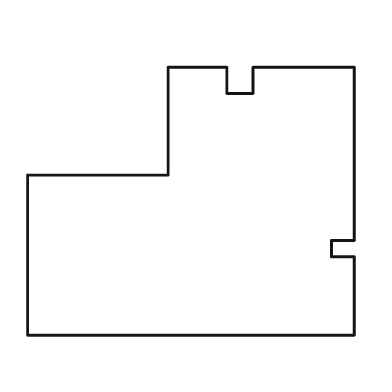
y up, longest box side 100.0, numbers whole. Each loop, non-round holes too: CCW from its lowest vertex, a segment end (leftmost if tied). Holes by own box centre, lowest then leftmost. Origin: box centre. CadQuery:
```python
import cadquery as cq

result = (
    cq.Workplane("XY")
    .moveTo(-50.0, -41.0)
    .lineTo(50.0, -41.0)
    .lineTo(50.0, -17.0)
    .lineTo(43.0, -17.0)
    .lineTo(43.0, -12.0)
    .lineTo(50.0, -12.0)
    .lineTo(50.0, 41.0)
    .lineTo(19.0, 41.0)
    .lineTo(19.0, 33.0)
    .lineTo(11.0, 33.0)
    .lineTo(11.0, 41.0)
    .lineTo(-7.0, 41.0)
    .lineTo(-7.0, 8.0)
    .lineTo(-50.0, 8.0)
    .close()
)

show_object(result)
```